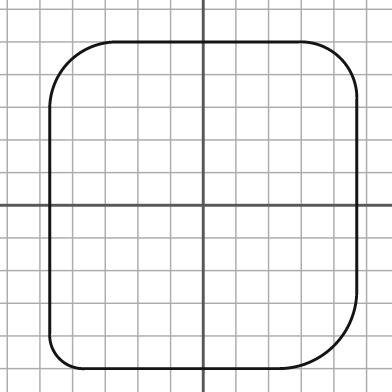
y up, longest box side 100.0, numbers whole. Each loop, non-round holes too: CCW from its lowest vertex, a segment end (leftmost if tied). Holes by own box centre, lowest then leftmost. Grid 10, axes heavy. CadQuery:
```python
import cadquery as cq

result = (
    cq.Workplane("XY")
    .moveTo(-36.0, -50.0)
    .lineTo(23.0, -50.0)
    .threePointArc((40.0, -43.0), (47.0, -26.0))
    .lineTo(47.0, 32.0)
    .threePointArc((42.0, 45.0), (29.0, 50.0))
    .lineTo(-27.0, 50.0)
    .threePointArc((-41.0, 44.0), (-47.0, 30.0))
    .lineTo(-47.0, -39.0)
    .threePointArc((-44.0, -47.0), (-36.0, -50.0))
    .close()
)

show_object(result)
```